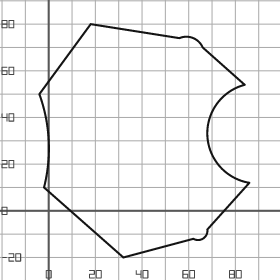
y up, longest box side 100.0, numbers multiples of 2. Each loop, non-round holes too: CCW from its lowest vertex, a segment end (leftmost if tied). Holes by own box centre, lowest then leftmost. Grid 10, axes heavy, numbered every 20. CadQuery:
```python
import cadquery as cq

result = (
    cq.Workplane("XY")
    .moveTo(32.0, -20.0)
    .lineTo(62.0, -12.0)
    .threePointArc((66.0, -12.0), (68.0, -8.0))
    .lineTo(86.0, 12.0)
    .threePointArc((68.0, 32.0), (84.0, 54.0))
    .lineTo(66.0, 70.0)
    .threePointArc((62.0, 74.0), (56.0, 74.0))
    .lineTo(18.0, 80.0)
    .lineTo(-4.0, 50.0)
    .threePointArc((0.0, 30.0), (-2.0, 10.0))
    .close()
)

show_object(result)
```